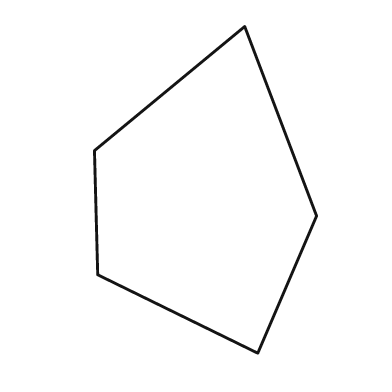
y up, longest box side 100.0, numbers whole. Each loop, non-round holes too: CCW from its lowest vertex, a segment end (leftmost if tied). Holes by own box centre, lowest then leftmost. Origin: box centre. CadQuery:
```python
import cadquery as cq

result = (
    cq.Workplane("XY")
    .moveTo(16.0, -50.0)
    .lineTo(34.0, -8.0)
    .lineTo(12.0, 50.0)
    .lineTo(-34.0, 12.0)
    .lineTo(-33.0, -26.0)
    .close()
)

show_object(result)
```